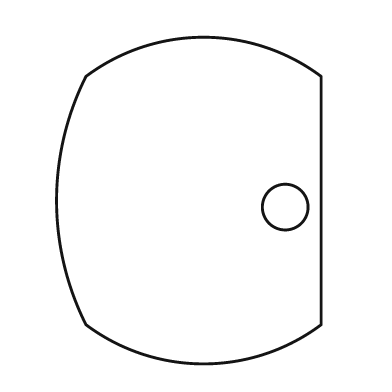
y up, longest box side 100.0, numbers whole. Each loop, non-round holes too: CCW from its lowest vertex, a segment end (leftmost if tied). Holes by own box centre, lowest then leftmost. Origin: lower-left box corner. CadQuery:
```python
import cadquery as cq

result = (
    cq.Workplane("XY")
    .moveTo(9.0, 12.0)
    .threePointArc((45.0, 0.0), (81.0, 12.0))
    .lineTo(81.0, 88.0)
    .threePointArc((45.0, 100.0), (9.0, 88.0))
    .threePointArc((0.0, 50.0), (9.0, 12.0))
    .close()
    .moveTo(70.0, 48.0)
    .circle(7.0)
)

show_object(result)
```